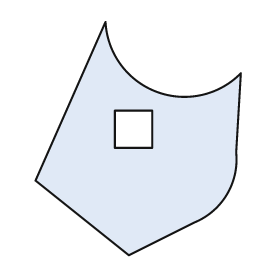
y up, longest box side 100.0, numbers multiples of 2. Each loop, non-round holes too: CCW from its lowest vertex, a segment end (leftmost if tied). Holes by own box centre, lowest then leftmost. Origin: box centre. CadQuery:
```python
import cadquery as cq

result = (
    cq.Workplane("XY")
    .moveTo(-4.0, -50.0)
    .lineTo(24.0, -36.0)
    .threePointArc((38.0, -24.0), (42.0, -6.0))
    .lineTo(44.0, 28.0)
    .threePointArc((8.0, 20.0), (-14.0, 50.0))
    .lineTo(-44.0, -18.0)
    .close()
    .moveTo(-10.0, -4.0)
    .lineTo(6.0, -4.0)
    .lineTo(6.0, 12.0)
    .lineTo(-10.0, 12.0)
    .close()
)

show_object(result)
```